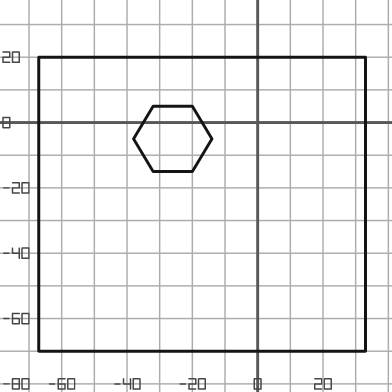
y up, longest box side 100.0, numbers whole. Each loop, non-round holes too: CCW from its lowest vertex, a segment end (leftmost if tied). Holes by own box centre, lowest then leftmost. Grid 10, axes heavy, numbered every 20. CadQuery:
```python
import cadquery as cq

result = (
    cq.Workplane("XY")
    .moveTo(-67.0, -70.0)
    .lineTo(33.0, -70.0)
    .lineTo(33.0, 20.0)
    .lineTo(-67.0, 20.0)
    .close()
    .moveTo(-32.0, -15.0)
    .lineTo(-20.0, -15.0)
    .lineTo(-14.0, -5.0)
    .lineTo(-20.0, 5.0)
    .lineTo(-32.0, 5.0)
    .lineTo(-38.0, -5.0)
    .close()
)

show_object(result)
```